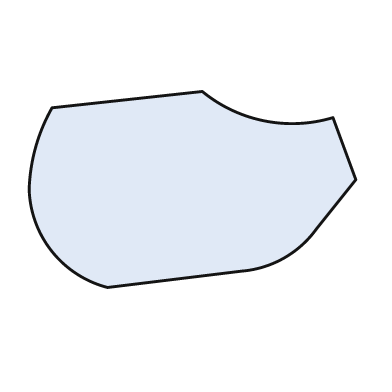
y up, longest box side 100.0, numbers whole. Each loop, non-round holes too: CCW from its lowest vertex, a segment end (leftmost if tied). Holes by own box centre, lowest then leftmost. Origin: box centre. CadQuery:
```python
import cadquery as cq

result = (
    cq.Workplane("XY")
    .moveTo(-26.0, -30.0)
    .lineTo(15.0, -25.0)
    .threePointArc((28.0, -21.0), (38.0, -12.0))
    .lineTo(50.0, 3.0)
    .lineTo(43.0, 22.0)
    .threePointArc((22.0, 21.0), (3.0, 30.0))
    .lineTo(-43.0, 25.0)
    .threePointArc((-48.0, 13.0), (-50.0, 0.0))
    .threePointArc((-43.0, -19.0), (-26.0, -30.0))
    .close()
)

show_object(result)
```